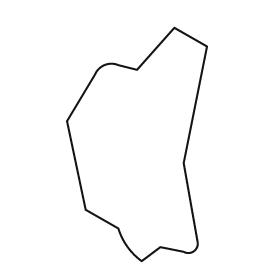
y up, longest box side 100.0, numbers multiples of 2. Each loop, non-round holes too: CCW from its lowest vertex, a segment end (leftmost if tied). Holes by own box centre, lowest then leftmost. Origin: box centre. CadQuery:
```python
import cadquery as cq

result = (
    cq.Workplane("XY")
    .moveTo(2.0, -50.0)
    .lineTo(10.0, -44.0)
    .lineTo(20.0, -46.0)
    .threePointArc((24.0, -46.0), (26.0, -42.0))
    .lineTo(20.0, -8.0)
    .lineTo(30.0, 42.0)
    .lineTo(16.0, 50.0)
    .lineTo(0.0, 32.0)
    .lineTo(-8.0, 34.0)
    .threePointArc((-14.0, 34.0), (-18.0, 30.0))
    .lineTo(-30.0, 10.0)
    .lineTo(-22.0, -28.0)
    .lineTo(-8.0, -36.0)
    .threePointArc((-4.0, -44.0), (2.0, -50.0))
    .close()
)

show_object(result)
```